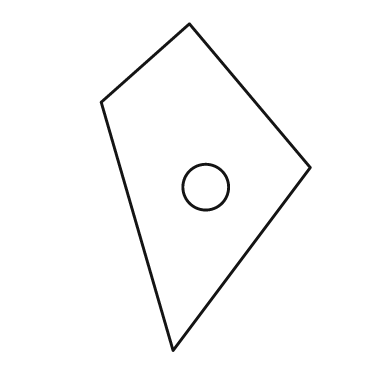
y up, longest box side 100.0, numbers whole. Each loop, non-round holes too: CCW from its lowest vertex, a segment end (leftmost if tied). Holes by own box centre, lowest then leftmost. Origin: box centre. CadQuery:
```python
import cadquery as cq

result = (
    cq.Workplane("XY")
    .moveTo(-10.0, -50.0)
    .lineTo(32.0, 6.0)
    .lineTo(-5.0, 50.0)
    .lineTo(-32.0, 26.0)
    .close()
    .moveTo(0.0, 0.0)
    .circle(7.0)
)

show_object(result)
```